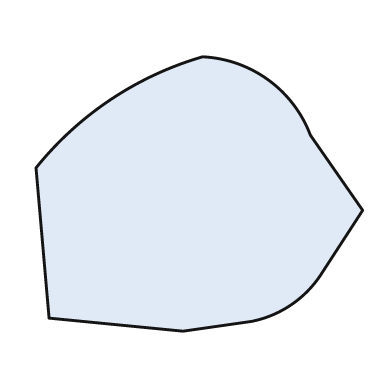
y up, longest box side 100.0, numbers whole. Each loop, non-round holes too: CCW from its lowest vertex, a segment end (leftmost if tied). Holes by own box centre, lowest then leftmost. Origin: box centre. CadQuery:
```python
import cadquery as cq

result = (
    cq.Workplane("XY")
    .moveTo(-5.0, -42.0)
    .lineTo(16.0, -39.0)
    .threePointArc((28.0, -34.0), (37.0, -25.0))
    .lineTo(50.0, -5.0)
    .lineTo(34.0, 18.0)
    .threePointArc((21.0, 35.0), (1.0, 42.0))
    .threePointArc((-27.0, 29.0), (-50.0, 8.0))
    .lineTo(-46.0, -38.0)
    .close()
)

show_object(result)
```